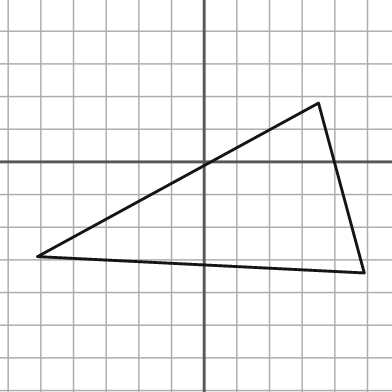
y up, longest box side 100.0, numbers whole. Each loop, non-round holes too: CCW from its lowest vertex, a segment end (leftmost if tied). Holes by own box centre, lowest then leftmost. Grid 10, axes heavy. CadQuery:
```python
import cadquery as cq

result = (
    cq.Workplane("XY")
    .moveTo(49.0, -34.0)
    .lineTo(35.0, 18.0)
    .lineTo(-51.0, -29.0)
    .close()
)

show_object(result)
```